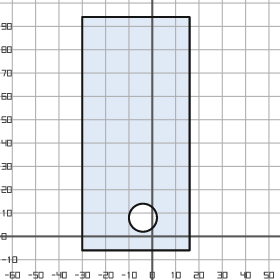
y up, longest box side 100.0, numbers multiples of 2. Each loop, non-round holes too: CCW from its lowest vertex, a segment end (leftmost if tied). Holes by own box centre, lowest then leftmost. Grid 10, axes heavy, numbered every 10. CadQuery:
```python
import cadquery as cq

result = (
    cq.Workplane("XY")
    .moveTo(-30.0, -6.0)
    .lineTo(16.0, -6.0)
    .lineTo(16.0, 94.0)
    .lineTo(-30.0, 94.0)
    .close()
    .moveTo(-4.0, 8.0)
    .circle(6.0)
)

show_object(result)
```